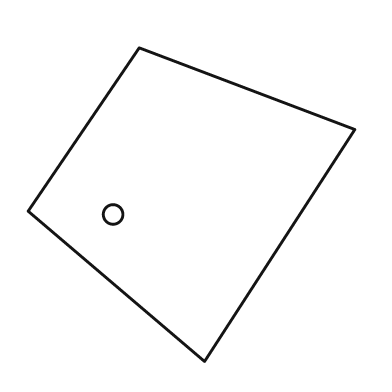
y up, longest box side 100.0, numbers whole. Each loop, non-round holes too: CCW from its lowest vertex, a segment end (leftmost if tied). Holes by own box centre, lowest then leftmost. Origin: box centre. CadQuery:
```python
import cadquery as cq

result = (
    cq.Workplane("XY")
    .moveTo(4.0, -48.0)
    .lineTo(50.0, 23.0)
    .lineTo(-16.0, 48.0)
    .lineTo(-50.0, -2.0)
    .close()
    .moveTo(-24.0, -3.0)
    .circle(3.0)
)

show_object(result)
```